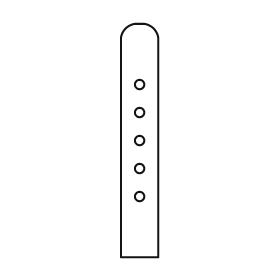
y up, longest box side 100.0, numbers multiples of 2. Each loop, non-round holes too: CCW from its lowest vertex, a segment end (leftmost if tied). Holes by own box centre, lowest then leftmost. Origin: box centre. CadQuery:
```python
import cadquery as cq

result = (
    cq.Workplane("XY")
    .moveTo(-8.0, -50.0)
    .lineTo(8.0, -50.0)
    .lineTo(8.0, 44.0)
    .threePointArc((6.0, 48.0), (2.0, 50.0))
    .lineTo(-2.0, 50.0)
    .threePointArc((-6.0, 48.0), (-8.0, 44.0))
    .close()
    .moveTo(0.0, -24.0)
    .circle(2.0)
    .moveTo(0.0, -12.0)
    .circle(2.0)
    .moveTo(0.0, 0.0)
    .circle(2.0)
    .moveTo(0.0, 12.0)
    .circle(2.0)
    .moveTo(0.0, 24.0)
    .circle(2.0)
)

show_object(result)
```